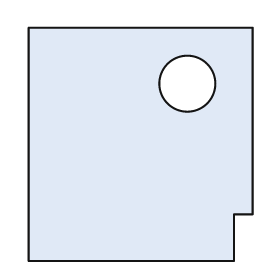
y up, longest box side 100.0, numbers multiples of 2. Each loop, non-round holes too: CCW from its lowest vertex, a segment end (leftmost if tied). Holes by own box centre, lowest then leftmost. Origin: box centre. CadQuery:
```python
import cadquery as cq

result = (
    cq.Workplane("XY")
    .moveTo(-48.0, -50.0)
    .lineTo(40.0, -50.0)
    .lineTo(40.0, -30.0)
    .lineTo(48.0, -30.0)
    .lineTo(48.0, 50.0)
    .lineTo(-48.0, 50.0)
    .close()
    .moveTo(20.0, 26.0)
    .circle(12.0)
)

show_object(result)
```